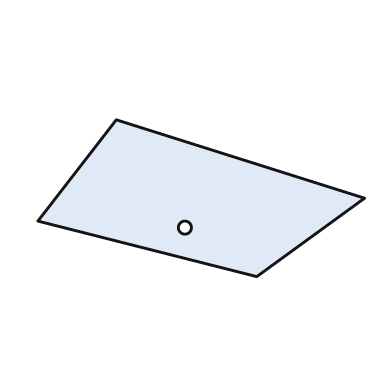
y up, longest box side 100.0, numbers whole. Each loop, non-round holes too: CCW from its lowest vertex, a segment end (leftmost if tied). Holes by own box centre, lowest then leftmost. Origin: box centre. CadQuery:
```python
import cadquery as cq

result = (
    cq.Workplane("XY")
    .moveTo(17.0, -24.0)
    .lineTo(50.0, 0.0)
    .lineTo(-26.0, 24.0)
    .lineTo(-50.0, -7.0)
    .close()
    .moveTo(-5.0, -9.0)
    .circle(2.0)
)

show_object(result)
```